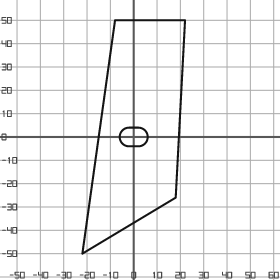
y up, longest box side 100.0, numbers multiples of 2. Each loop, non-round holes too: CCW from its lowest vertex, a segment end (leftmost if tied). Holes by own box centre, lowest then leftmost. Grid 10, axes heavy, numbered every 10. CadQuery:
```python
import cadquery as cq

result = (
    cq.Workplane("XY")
    .moveTo(-22.0, -50.0)
    .lineTo(18.0, -26.0)
    .lineTo(22.0, 50.0)
    .lineTo(-8.0, 50.0)
    .close()
    .moveTo(-2.0, -4.0)
    .lineTo(2.0, -4.0)
    .threePointArc((6.0, 0.0), (2.0, 4.0))
    .lineTo(-2.0, 4.0)
    .threePointArc((-6.0, 0.0), (-2.0, -4.0))
    .close()
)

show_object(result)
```